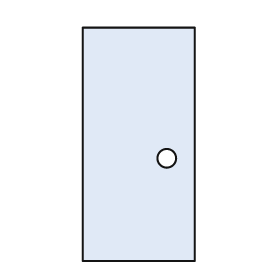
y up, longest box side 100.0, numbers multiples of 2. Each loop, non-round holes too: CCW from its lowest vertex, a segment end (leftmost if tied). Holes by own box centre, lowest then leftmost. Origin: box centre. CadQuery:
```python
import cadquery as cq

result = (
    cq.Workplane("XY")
    .moveTo(-24.0, -50.0)
    .lineTo(24.0, -50.0)
    .lineTo(24.0, 50.0)
    .lineTo(-24.0, 50.0)
    .close()
    .moveTo(12.0, -6.0)
    .circle(4.0)
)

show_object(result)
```